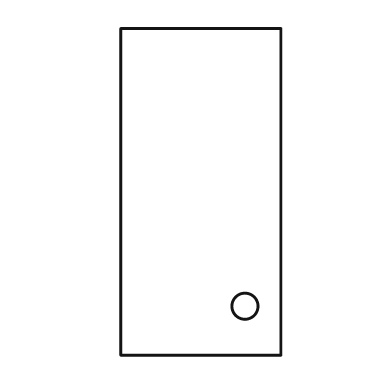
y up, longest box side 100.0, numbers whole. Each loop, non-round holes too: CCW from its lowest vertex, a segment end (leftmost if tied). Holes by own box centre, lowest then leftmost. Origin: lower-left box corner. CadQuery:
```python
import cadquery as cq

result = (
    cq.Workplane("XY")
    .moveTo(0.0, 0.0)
    .lineTo(49.0, 0.0)
    .lineTo(49.0, 100.0)
    .lineTo(0.0, 100.0)
    .close()
    .moveTo(38.0, 15.0)
    .circle(4.0)
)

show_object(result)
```